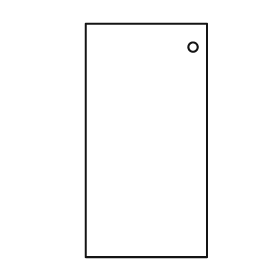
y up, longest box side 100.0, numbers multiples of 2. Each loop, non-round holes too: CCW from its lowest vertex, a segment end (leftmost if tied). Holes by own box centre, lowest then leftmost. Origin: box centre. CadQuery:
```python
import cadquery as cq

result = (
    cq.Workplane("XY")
    .moveTo(-26.0, -50.0)
    .lineTo(26.0, -50.0)
    .lineTo(26.0, 50.0)
    .lineTo(-26.0, 50.0)
    .close()
    .moveTo(20.0, 40.0)
    .circle(2.0)
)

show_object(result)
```